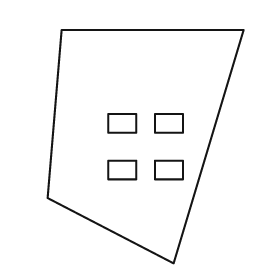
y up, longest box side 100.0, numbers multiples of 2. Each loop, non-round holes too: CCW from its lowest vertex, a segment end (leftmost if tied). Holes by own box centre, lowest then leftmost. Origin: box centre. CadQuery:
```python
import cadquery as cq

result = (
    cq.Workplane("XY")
    .moveTo(12.0, -50.0)
    .lineTo(42.0, 50.0)
    .lineTo(-36.0, 50.0)
    .lineTo(-42.0, -22.0)
    .close()
    .moveTo(-16.0, -14.0)
    .lineTo(-4.0, -14.0)
    .lineTo(-4.0, -6.0)
    .lineTo(-16.0, -6.0)
    .close()
    .moveTo(4.0, -14.0)
    .lineTo(16.0, -14.0)
    .lineTo(16.0, -6.0)
    .lineTo(4.0, -6.0)
    .close()
    .moveTo(-16.0, 6.0)
    .lineTo(-4.0, 6.0)
    .lineTo(-4.0, 14.0)
    .lineTo(-16.0, 14.0)
    .close()
    .moveTo(4.0, 6.0)
    .lineTo(16.0, 6.0)
    .lineTo(16.0, 14.0)
    .lineTo(4.0, 14.0)
    .close()
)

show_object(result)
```